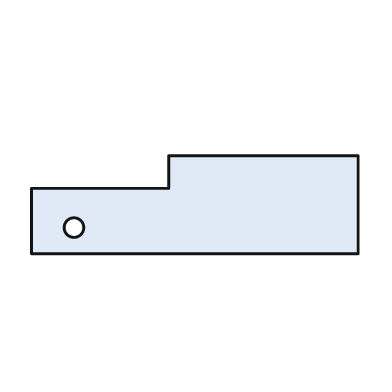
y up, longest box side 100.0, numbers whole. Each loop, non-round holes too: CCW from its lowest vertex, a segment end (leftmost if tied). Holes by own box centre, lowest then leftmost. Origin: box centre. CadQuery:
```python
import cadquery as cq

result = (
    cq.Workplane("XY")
    .moveTo(-50.0, -15.0)
    .lineTo(50.0, -15.0)
    .lineTo(50.0, 15.0)
    .lineTo(-8.0, 15.0)
    .lineTo(-8.0, 5.0)
    .lineTo(-50.0, 5.0)
    .close()
    .moveTo(-37.0, -7.0)
    .circle(3.0)
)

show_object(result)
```